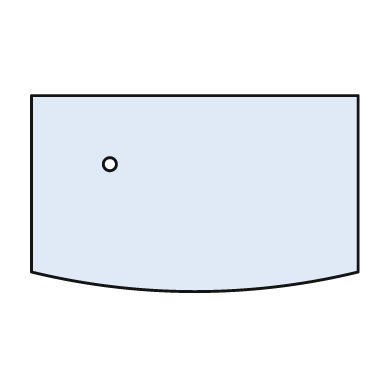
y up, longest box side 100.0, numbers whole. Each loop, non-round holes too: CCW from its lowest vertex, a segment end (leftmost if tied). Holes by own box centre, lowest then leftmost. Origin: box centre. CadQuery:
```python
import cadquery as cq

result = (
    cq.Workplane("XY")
    .moveTo(-50.0, -24.0)
    .threePointArc((0.0, -30.0), (50.0, -24.0))
    .lineTo(50.0, 30.0)
    .lineTo(-50.0, 30.0)
    .close()
    .moveTo(-26.0, 9.0)
    .circle(2.0)
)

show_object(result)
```